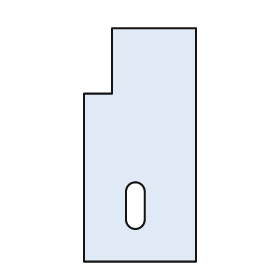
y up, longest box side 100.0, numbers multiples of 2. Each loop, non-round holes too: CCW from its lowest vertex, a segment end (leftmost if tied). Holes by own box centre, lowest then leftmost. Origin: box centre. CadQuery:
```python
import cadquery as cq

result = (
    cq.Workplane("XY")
    .moveTo(-24.0, -50.0)
    .lineTo(24.0, -50.0)
    .lineTo(24.0, 50.0)
    .lineTo(-12.0, 50.0)
    .lineTo(-12.0, 22.0)
    .lineTo(-24.0, 22.0)
    .close()
    .moveTo(-6.0, -32.0)
    .threePointArc((-2.0, -36.0), (2.0, -32.0))
    .lineTo(2.0, -20.0)
    .threePointArc((-2.0, -16.0), (-6.0, -20.0))
    .close()
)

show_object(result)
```